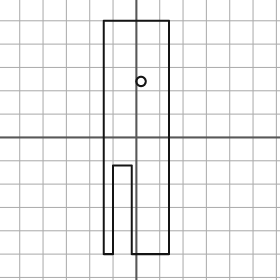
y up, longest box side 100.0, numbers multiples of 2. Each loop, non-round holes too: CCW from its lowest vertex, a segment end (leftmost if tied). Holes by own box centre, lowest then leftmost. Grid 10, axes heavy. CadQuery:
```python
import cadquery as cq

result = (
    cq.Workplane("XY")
    .moveTo(-14.0, -50.0)
    .lineTo(-10.0, -50.0)
    .lineTo(-10.0, -12.0)
    .lineTo(-2.0, -12.0)
    .lineTo(-2.0, -50.0)
    .lineTo(14.0, -50.0)
    .lineTo(14.0, 50.0)
    .lineTo(-14.0, 50.0)
    .close()
    .moveTo(2.0, 24.0)
    .circle(2.0)
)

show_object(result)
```